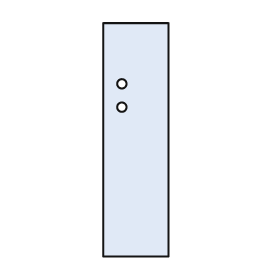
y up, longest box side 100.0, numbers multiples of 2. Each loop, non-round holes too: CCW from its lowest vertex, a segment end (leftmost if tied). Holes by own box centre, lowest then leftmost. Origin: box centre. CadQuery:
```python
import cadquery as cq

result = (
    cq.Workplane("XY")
    .moveTo(-14.0, -50.0)
    .lineTo(14.0, -50.0)
    .lineTo(14.0, 50.0)
    .lineTo(-14.0, 50.0)
    .close()
    .moveTo(-6.0, 14.0)
    .circle(2.0)
    .moveTo(-6.0, 24.0)
    .circle(2.0)
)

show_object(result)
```